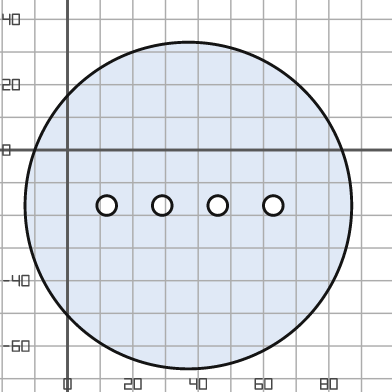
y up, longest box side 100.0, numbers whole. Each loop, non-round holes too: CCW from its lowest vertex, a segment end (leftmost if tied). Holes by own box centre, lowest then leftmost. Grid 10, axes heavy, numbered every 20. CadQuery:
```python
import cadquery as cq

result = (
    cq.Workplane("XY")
    .moveTo(37.0, -17.0)
    .circle(50.0)
    .moveTo(12.0, -17.0)
    .circle(3.0)
    .moveTo(29.0, -17.0)
    .circle(3.0)
    .moveTo(46.0, -17.0)
    .circle(3.0)
    .moveTo(63.0, -17.0)
    .circle(3.0)
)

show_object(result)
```